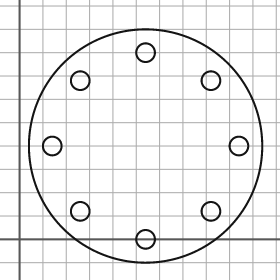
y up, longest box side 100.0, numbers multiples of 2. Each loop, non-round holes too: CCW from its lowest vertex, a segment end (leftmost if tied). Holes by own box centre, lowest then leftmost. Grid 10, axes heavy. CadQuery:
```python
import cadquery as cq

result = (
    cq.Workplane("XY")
    .moveTo(54.0, 40.0)
    .circle(50.0)
    .moveTo(54.0, 0.0)
    .circle(4.0)
    .moveTo(26.0, 12.0)
    .circle(4.0)
    .moveTo(82.0, 12.0)
    .circle(4.0)
    .moveTo(14.0, 40.0)
    .circle(4.0)
    .moveTo(94.0, 40.0)
    .circle(4.0)
    .moveTo(26.0, 68.0)
    .circle(4.0)
    .moveTo(82.0, 68.0)
    .circle(4.0)
    .moveTo(54.0, 80.0)
    .circle(4.0)
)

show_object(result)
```